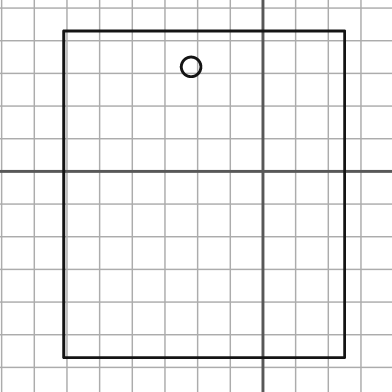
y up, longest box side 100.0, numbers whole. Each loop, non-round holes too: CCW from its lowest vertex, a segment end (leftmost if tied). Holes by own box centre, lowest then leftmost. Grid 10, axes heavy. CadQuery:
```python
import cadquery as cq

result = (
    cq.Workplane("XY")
    .moveTo(-61.0, -57.0)
    .lineTo(25.0, -57.0)
    .lineTo(25.0, 43.0)
    .lineTo(-61.0, 43.0)
    .close()
    .moveTo(-22.0, 32.0)
    .circle(3.0)
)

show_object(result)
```